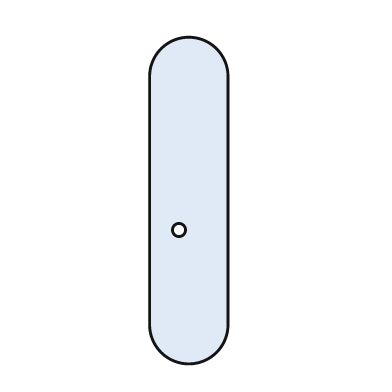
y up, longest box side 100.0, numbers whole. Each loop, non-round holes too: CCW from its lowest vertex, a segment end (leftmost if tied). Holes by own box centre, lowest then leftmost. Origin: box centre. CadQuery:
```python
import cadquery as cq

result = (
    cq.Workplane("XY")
    .moveTo(-12.0, -38.0)
    .threePointArc((0.0, -50.0), (12.0, -38.0))
    .lineTo(12.0, 38.0)
    .threePointArc((0.0, 50.0), (-12.0, 38.0))
    .close()
    .moveTo(-3.0, -9.0)
    .circle(2.0)
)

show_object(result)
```